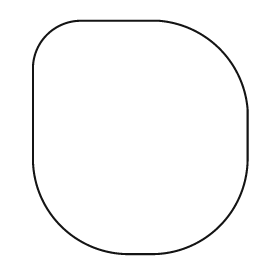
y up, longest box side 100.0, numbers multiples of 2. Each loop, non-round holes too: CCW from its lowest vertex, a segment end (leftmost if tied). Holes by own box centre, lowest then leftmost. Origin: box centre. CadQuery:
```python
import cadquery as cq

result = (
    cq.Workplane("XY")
    .moveTo(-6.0, -50.0)
    .lineTo(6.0, -50.0)
    .threePointArc((34.0, -38.0), (46.0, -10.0))
    .lineTo(46.0, 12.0)
    .threePointArc((34.0, 38.0), (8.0, 50.0))
    .lineTo(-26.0, 50.0)
    .threePointArc((-40.0, 44.0), (-46.0, 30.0))
    .lineTo(-46.0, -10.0)
    .threePointArc((-34.0, -38.0), (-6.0, -50.0))
    .close()
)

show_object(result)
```